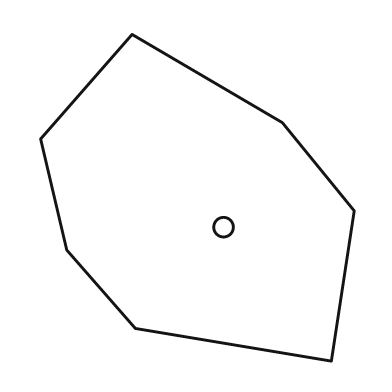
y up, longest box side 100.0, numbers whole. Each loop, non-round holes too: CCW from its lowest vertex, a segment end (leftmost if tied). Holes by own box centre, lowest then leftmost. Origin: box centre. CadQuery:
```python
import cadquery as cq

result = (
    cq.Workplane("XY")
    .moveTo(41.0, -50.0)
    .lineTo(48.0, -4.0)
    .lineTo(26.0, 23.0)
    .lineTo(-20.0, 50.0)
    .lineTo(-48.0, 18.0)
    .lineTo(-40.0, -16.0)
    .lineTo(-19.0, -40.0)
    .close()
    .moveTo(8.0, -9.0)
    .circle(3.0)
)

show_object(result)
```